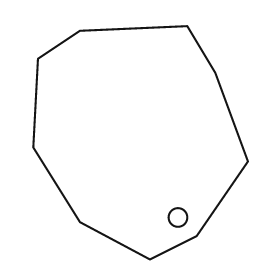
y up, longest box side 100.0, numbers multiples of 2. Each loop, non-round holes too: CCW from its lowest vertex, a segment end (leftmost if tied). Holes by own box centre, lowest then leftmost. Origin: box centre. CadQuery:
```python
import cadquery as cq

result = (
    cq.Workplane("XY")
    .moveTo(4.0, -50.0)
    .lineTo(24.0, -40.0)
    .lineTo(46.0, -8.0)
    .lineTo(32.0, 30.0)
    .lineTo(20.0, 50.0)
    .lineTo(-26.0, 48.0)
    .lineTo(-44.0, 36.0)
    .lineTo(-46.0, -2.0)
    .lineTo(-26.0, -34.0)
    .close()
    .moveTo(16.0, -32.0)
    .circle(4.0)
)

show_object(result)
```